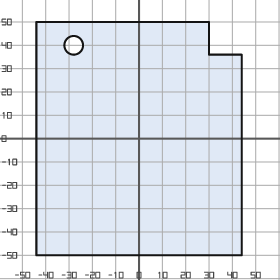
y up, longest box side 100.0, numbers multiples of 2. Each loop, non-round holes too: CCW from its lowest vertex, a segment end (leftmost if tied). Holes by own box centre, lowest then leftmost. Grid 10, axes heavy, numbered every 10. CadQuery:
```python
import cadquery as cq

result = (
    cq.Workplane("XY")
    .moveTo(-44.0, -50.0)
    .lineTo(44.0, -50.0)
    .lineTo(44.0, 36.0)
    .lineTo(30.0, 36.0)
    .lineTo(30.0, 50.0)
    .lineTo(-44.0, 50.0)
    .close()
    .moveTo(-28.0, 40.0)
    .circle(4.0)
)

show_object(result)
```